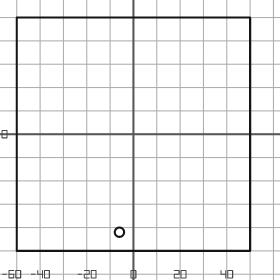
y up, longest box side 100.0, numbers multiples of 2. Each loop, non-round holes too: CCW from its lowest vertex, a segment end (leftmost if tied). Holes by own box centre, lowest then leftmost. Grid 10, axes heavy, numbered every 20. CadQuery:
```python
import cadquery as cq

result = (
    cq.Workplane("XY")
    .moveTo(-50.0, -50.0)
    .lineTo(50.0, -50.0)
    .lineTo(50.0, 50.0)
    .lineTo(-50.0, 50.0)
    .close()
    .moveTo(-6.0, -42.0)
    .circle(2.0)
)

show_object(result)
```